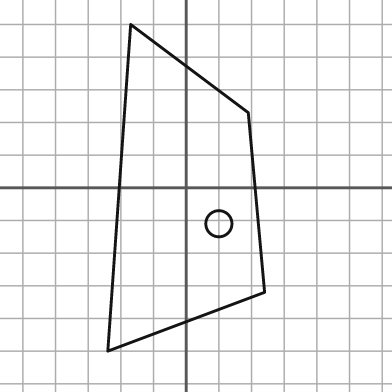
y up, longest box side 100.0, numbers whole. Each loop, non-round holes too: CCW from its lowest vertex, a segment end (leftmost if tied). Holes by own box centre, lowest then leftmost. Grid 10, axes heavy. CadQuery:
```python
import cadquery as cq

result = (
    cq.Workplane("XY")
    .moveTo(-24.0, -50.0)
    .lineTo(24.0, -32.0)
    .lineTo(19.0, 23.0)
    .lineTo(-17.0, 50.0)
    .close()
    .moveTo(10.0, -11.0)
    .circle(4.0)
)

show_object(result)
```